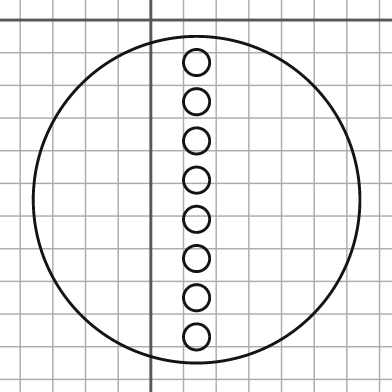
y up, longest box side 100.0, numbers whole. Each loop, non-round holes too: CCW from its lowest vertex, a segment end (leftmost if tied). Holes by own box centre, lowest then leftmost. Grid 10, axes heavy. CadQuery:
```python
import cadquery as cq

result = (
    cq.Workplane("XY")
    .moveTo(14.0, -55.0)
    .circle(50.0)
    .moveTo(14.0, -97.0)
    .circle(4.0)
    .moveTo(14.0, -85.0)
    .circle(4.0)
    .moveTo(14.0, -73.0)
    .circle(4.0)
    .moveTo(14.0, -61.0)
    .circle(4.0)
    .moveTo(14.0, -49.0)
    .circle(4.0)
    .moveTo(14.0, -37.0)
    .circle(4.0)
    .moveTo(14.0, -25.0)
    .circle(4.0)
    .moveTo(14.0, -13.0)
    .circle(4.0)
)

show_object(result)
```